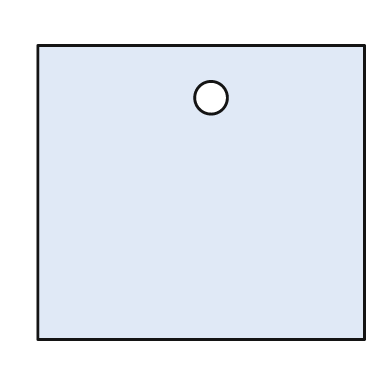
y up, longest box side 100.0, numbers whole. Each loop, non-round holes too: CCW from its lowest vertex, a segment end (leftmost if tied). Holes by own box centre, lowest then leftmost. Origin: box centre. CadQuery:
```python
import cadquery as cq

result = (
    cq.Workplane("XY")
    .moveTo(-50.0, -45.0)
    .lineTo(50.0, -45.0)
    .lineTo(50.0, 45.0)
    .lineTo(-50.0, 45.0)
    .close()
    .moveTo(3.0, 29.0)
    .circle(5.0)
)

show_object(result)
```